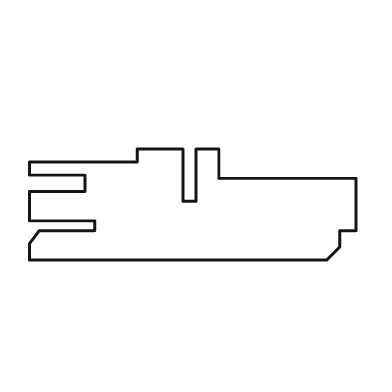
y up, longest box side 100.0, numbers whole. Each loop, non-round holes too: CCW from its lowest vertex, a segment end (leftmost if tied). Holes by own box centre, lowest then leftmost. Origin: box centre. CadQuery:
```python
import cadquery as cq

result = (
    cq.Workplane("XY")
    .moveTo(-50.0, -17.0)
    .lineTo(41.0, -17.0)
    .lineTo(45.0, -13.0)
    .lineTo(45.0, -8.0)
    .lineTo(50.0, -8.0)
    .lineTo(50.0, 8.0)
    .lineTo(8.0, 8.0)
    .lineTo(8.0, 17.0)
    .lineTo(1.0, 17.0)
    .lineTo(1.0, 1.0)
    .lineTo(-3.0, 1.0)
    .lineTo(-3.0, 17.0)
    .lineTo(-17.0, 17.0)
    .lineTo(-17.0, 13.0)
    .lineTo(-50.0, 13.0)
    .lineTo(-50.0, 9.0)
    .lineTo(-33.0, 9.0)
    .lineTo(-33.0, 4.0)
    .lineTo(-50.0, 4.0)
    .lineTo(-50.0, -5.0)
    .lineTo(-30.0, -5.0)
    .lineTo(-30.0, -8.0)
    .lineTo(-47.0, -8.0)
    .lineTo(-50.0, -12.0)
    .close()
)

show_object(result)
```